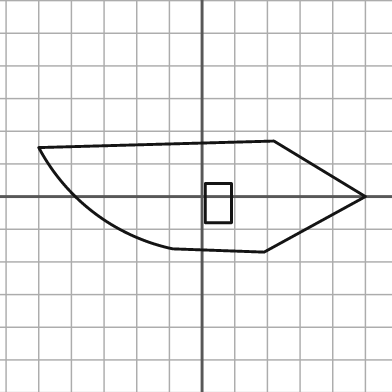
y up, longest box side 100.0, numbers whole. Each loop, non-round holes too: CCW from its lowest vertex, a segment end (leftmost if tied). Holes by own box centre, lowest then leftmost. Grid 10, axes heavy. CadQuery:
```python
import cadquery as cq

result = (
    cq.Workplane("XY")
    .moveTo(19.0, -17.0)
    .lineTo(50.0, 0.0)
    .lineTo(22.0, 17.0)
    .lineTo(-50.0, 15.0)
    .threePointArc((-33.0, -5.0), (-9.0, -16.0))
    .close()
    .moveTo(1.0, -8.0)
    .lineTo(9.0, -8.0)
    .lineTo(9.0, 4.0)
    .lineTo(1.0, 4.0)
    .close()
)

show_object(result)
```